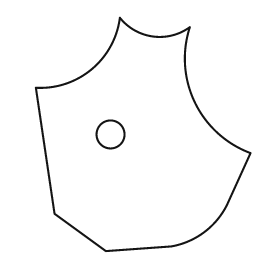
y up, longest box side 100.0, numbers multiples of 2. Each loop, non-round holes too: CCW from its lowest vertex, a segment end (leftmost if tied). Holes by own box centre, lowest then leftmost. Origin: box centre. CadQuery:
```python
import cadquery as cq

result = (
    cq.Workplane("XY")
    .moveTo(-16.0, -50.0)
    .lineTo(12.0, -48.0)
    .threePointArc((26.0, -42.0), (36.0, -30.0))
    .lineTo(46.0, -8.0)
    .threePointArc((22.0, 14.0), (20.0, 46.0))
    .threePointArc((4.0, 42.0), (-10.0, 50.0))
    .threePointArc((-22.0, 28.0), (-46.0, 20.0))
    .lineTo(-38.0, -34.0)
    .close()
    .moveTo(-14.0, 0.0)
    .circle(6.0)
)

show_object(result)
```